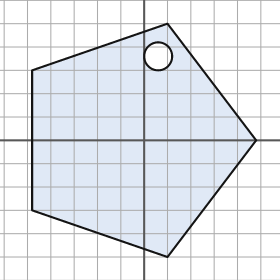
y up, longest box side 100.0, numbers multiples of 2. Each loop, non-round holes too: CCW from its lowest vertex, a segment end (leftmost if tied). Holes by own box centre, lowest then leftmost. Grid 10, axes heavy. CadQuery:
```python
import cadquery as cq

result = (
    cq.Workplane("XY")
    .moveTo(10.0, -50.0)
    .lineTo(48.0, 0.0)
    .lineTo(10.0, 50.0)
    .lineTo(-48.0, 30.0)
    .lineTo(-48.0, -30.0)
    .close()
    .moveTo(6.0, 36.0)
    .circle(6.0)
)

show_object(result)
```